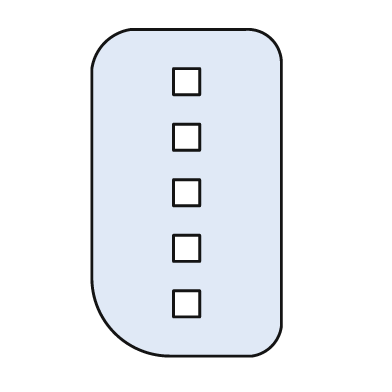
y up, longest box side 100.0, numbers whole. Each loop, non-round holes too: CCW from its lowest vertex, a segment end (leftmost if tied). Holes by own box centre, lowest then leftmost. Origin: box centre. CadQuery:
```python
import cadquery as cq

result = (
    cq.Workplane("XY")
    .moveTo(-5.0, -50.0)
    .lineTo(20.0, -50.0)
    .threePointArc((26.0, -47.0), (29.0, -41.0))
    .lineTo(29.0, 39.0)
    .threePointArc((26.0, 47.0), (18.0, 50.0))
    .lineTo(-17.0, 50.0)
    .threePointArc((-25.0, 46.0), (-29.0, 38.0))
    .lineTo(-29.0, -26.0)
    .threePointArc((-22.0, -43.0), (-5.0, -50.0))
    .close()
    .moveTo(-4.0, -38.0)
    .lineTo(4.0, -38.0)
    .lineTo(4.0, -30.0)
    .lineTo(-4.0, -30.0)
    .close()
    .moveTo(-4.0, -21.0)
    .lineTo(4.0, -21.0)
    .lineTo(4.0, -13.0)
    .lineTo(-4.0, -13.0)
    .close()
    .moveTo(-4.0, -4.0)
    .lineTo(4.0, -4.0)
    .lineTo(4.0, 4.0)
    .lineTo(-4.0, 4.0)
    .close()
    .moveTo(-4.0, 13.0)
    .lineTo(4.0, 13.0)
    .lineTo(4.0, 21.0)
    .lineTo(-4.0, 21.0)
    .close()
    .moveTo(-4.0, 30.0)
    .lineTo(4.0, 30.0)
    .lineTo(4.0, 38.0)
    .lineTo(-4.0, 38.0)
    .close()
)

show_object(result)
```